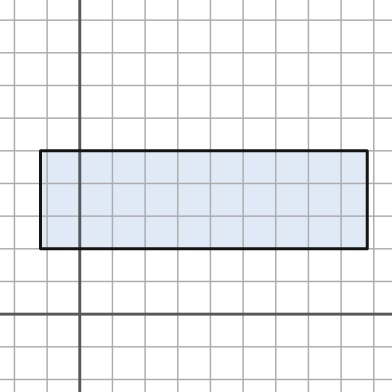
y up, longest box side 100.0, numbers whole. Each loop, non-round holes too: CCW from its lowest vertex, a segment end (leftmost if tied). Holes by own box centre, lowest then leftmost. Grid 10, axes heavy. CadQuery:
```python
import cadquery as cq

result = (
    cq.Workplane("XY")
    .moveTo(-12.0, 20.0)
    .lineTo(88.0, 20.0)
    .lineTo(88.0, 50.0)
    .lineTo(-12.0, 50.0)
    .close()
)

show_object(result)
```